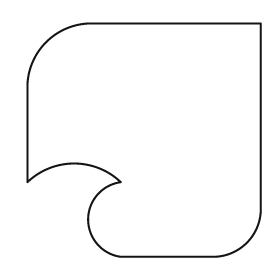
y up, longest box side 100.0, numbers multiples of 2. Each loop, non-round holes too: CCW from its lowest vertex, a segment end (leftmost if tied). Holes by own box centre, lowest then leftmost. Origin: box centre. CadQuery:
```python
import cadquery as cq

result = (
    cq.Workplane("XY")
    .moveTo(-10.0, -50.0)
    .lineTo(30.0, -50.0)
    .threePointArc((44.0, -44.0), (50.0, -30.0))
    .lineTo(50.0, 50.0)
    .lineTo(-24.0, 50.0)
    .threePointArc((-42.0, 42.0), (-50.0, 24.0))
    .lineTo(-50.0, -18.0)
    .threePointArc((-30.0, -10.0), (-10.0, -18.0))
    .threePointArc((-24.0, -34.0), (-10.0, -50.0))
    .close()
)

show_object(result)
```